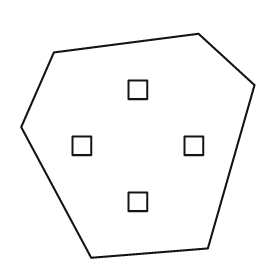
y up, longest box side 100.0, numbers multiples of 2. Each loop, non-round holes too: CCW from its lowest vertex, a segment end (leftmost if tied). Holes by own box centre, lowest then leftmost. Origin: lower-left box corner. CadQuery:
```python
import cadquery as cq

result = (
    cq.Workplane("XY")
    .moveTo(30.0, 0.0)
    .lineTo(80.0, 4.0)
    .lineTo(100.0, 74.0)
    .lineTo(76.0, 96.0)
    .lineTo(14.0, 88.0)
    .lineTo(0.0, 56.0)
    .close()
    .moveTo(46.0, 20.0)
    .lineTo(54.0, 20.0)
    .lineTo(54.0, 28.0)
    .lineTo(46.0, 28.0)
    .close()
    .moveTo(22.0, 44.0)
    .lineTo(30.0, 44.0)
    .lineTo(30.0, 52.0)
    .lineTo(22.0, 52.0)
    .close()
    .moveTo(70.0, 44.0)
    .lineTo(78.0, 44.0)
    .lineTo(78.0, 52.0)
    .lineTo(70.0, 52.0)
    .close()
    .moveTo(46.0, 68.0)
    .lineTo(54.0, 68.0)
    .lineTo(54.0, 76.0)
    .lineTo(46.0, 76.0)
    .close()
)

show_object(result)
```